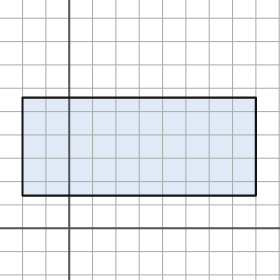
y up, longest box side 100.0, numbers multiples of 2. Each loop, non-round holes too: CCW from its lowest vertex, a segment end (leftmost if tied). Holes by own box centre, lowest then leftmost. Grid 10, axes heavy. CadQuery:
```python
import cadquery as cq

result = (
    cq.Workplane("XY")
    .moveTo(-20.0, 14.0)
    .lineTo(80.0, 14.0)
    .lineTo(80.0, 56.0)
    .lineTo(-20.0, 56.0)
    .close()
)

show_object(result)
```